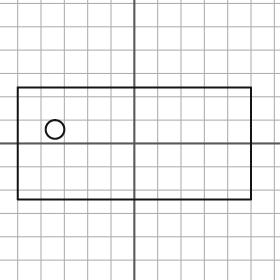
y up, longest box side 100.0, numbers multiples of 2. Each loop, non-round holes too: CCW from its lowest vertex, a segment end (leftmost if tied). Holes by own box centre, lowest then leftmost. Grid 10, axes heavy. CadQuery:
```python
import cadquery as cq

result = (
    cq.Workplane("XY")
    .moveTo(-50.0, -24.0)
    .lineTo(50.0, -24.0)
    .lineTo(50.0, 24.0)
    .lineTo(-50.0, 24.0)
    .close()
    .moveTo(-34.0, 6.0)
    .circle(4.0)
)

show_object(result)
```